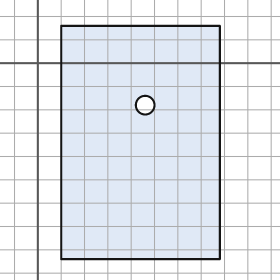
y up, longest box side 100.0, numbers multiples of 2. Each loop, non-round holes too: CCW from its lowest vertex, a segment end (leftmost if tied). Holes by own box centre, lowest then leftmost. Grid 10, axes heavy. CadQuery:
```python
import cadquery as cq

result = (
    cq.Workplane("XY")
    .moveTo(10.0, -84.0)
    .lineTo(78.0, -84.0)
    .lineTo(78.0, 16.0)
    .lineTo(10.0, 16.0)
    .close()
    .moveTo(46.0, -18.0)
    .circle(4.0)
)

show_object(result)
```